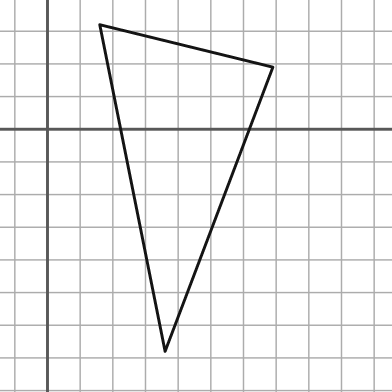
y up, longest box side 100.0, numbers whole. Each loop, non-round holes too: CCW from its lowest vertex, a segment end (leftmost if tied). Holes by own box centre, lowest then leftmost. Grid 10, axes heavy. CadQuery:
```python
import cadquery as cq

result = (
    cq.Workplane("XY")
    .moveTo(36.0, -68.0)
    .lineTo(69.0, 19.0)
    .lineTo(16.0, 32.0)
    .close()
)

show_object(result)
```